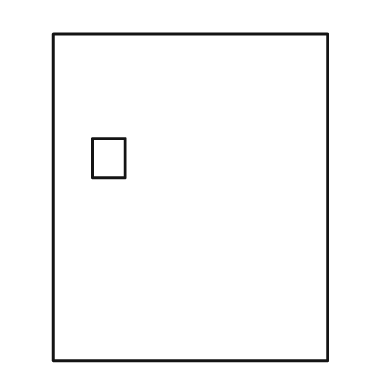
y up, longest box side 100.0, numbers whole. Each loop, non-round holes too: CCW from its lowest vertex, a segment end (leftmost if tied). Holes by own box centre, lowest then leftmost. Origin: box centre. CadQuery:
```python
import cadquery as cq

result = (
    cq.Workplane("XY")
    .moveTo(-42.0, -50.0)
    .lineTo(42.0, -50.0)
    .lineTo(42.0, 50.0)
    .lineTo(-42.0, 50.0)
    .close()
    .moveTo(-30.0, 6.0)
    .lineTo(-20.0, 6.0)
    .lineTo(-20.0, 18.0)
    .lineTo(-30.0, 18.0)
    .close()
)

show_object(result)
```